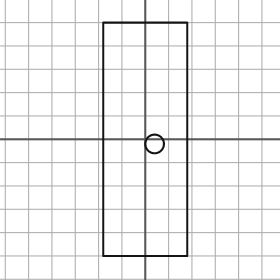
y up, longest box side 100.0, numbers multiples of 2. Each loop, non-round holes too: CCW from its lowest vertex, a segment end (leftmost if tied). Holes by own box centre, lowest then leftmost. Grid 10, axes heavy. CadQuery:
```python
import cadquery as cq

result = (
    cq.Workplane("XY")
    .moveTo(-18.0, -50.0)
    .lineTo(18.0, -50.0)
    .lineTo(18.0, 50.0)
    .lineTo(-18.0, 50.0)
    .close()
    .moveTo(4.0, -2.0)
    .circle(4.0)
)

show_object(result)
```